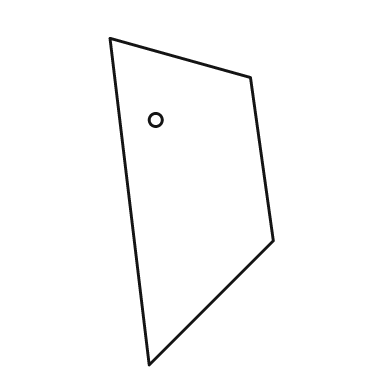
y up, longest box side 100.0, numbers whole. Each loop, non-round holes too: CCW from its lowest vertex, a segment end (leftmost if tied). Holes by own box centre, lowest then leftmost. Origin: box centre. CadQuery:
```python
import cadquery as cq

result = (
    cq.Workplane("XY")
    .moveTo(-13.0, -50.0)
    .lineTo(25.0, -12.0)
    .lineTo(18.0, 38.0)
    .lineTo(-25.0, 50.0)
    .close()
    .moveTo(-11.0, 25.0)
    .circle(2.0)
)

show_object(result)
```